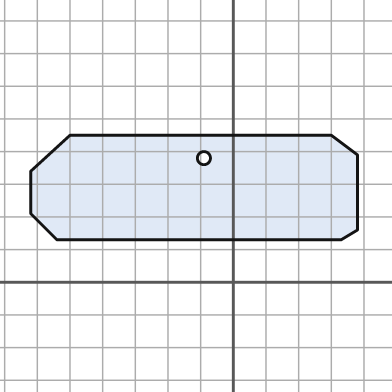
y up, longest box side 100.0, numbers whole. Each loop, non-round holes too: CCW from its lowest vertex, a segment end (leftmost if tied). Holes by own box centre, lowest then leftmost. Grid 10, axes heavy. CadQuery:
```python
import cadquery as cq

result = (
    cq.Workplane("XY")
    .moveTo(-54.0, 13.0)
    .lineTo(33.0, 13.0)
    .lineTo(38.0, 16.0)
    .lineTo(38.0, 39.0)
    .lineTo(30.0, 45.0)
    .lineTo(-50.0, 45.0)
    .lineTo(-62.0, 34.0)
    .lineTo(-62.0, 21.0)
    .close()
    .moveTo(-9.0, 38.0)
    .circle(2.0)
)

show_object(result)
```